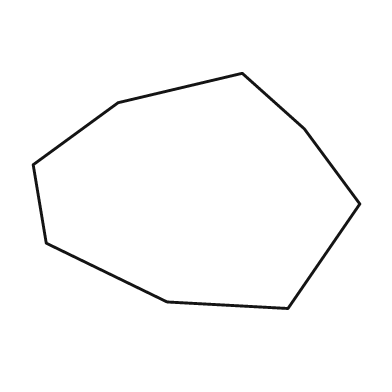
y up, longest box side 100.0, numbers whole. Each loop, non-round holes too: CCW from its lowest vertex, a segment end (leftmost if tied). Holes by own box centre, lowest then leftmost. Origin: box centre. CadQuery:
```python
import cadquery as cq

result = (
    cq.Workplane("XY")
    .moveTo(28.0, -36.0)
    .lineTo(50.0, -4.0)
    .lineTo(33.0, 19.0)
    .lineTo(14.0, 36.0)
    .lineTo(-24.0, 27.0)
    .lineTo(-50.0, 8.0)
    .lineTo(-46.0, -16.0)
    .lineTo(-9.0, -34.0)
    .close()
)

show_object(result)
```